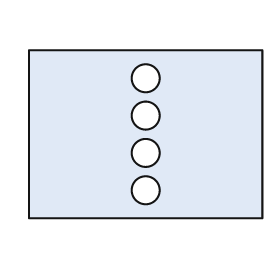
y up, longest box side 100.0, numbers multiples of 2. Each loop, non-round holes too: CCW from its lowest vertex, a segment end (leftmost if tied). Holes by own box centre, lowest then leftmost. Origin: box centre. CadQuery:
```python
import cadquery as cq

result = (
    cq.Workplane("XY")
    .moveTo(-50.0, -36.0)
    .lineTo(50.0, -36.0)
    .lineTo(50.0, 36.0)
    .lineTo(-50.0, 36.0)
    .close()
    .moveTo(0.0, -24.0)
    .circle(6.0)
    .moveTo(0.0, -8.0)
    .circle(6.0)
    .moveTo(0.0, 8.0)
    .circle(6.0)
    .moveTo(0.0, 24.0)
    .circle(6.0)
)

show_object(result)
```